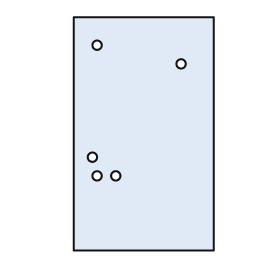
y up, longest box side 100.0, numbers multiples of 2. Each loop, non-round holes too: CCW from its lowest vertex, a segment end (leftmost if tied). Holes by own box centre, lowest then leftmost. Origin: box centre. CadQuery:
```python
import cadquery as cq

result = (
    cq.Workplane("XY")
    .moveTo(-30.0, -50.0)
    .lineTo(30.0, -50.0)
    .lineTo(30.0, 50.0)
    .lineTo(-30.0, 50.0)
    .close()
    .moveTo(-20.0, -18.0)
    .circle(2.0)
    .moveTo(-12.0, -18.0)
    .circle(2.0)
    .moveTo(-22.0, -10.0)
    .circle(2.0)
    .moveTo(16.0, 30.0)
    .circle(2.0)
    .moveTo(-20.0, 38.0)
    .circle(2.0)
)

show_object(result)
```